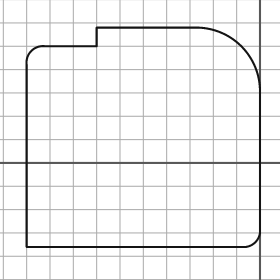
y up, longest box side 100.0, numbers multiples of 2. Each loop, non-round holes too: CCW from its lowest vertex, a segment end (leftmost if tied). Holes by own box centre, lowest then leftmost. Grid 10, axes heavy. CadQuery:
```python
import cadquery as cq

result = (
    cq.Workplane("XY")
    .moveTo(-100.0, -36.0)
    .lineTo(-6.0, -36.0)
    .threePointArc((-2.0, -34.0), (0.0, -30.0))
    .lineTo(0.0, 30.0)
    .threePointArc((-8.0, 50.0), (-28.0, 58.0))
    .lineTo(-70.0, 58.0)
    .lineTo(-70.0, 50.0)
    .lineTo(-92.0, 50.0)
    .threePointArc((-98.0, 48.0), (-100.0, 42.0))
    .close()
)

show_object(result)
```